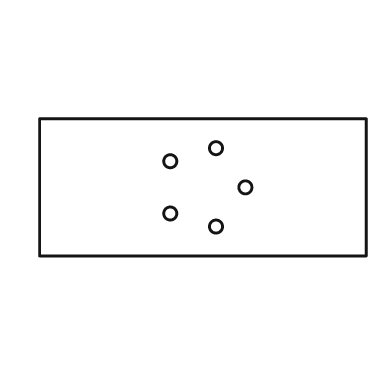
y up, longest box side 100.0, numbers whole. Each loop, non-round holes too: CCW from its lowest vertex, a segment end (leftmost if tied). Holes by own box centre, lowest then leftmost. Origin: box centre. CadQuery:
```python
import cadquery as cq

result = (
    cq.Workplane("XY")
    .moveTo(-50.0, -21.0)
    .lineTo(50.0, -21.0)
    .lineTo(50.0, 21.0)
    .lineTo(-50.0, 21.0)
    .close()
    .moveTo(4.0, -12.0)
    .circle(2.0)
    .moveTo(-10.0, -8.0)
    .circle(2.0)
    .moveTo(13.0, 0.0)
    .circle(2.0)
    .moveTo(-10.0, 8.0)
    .circle(2.0)
    .moveTo(4.0, 12.0)
    .circle(2.0)
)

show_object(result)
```